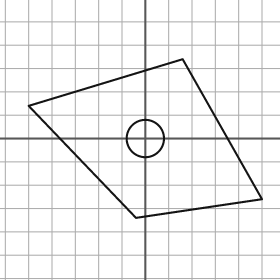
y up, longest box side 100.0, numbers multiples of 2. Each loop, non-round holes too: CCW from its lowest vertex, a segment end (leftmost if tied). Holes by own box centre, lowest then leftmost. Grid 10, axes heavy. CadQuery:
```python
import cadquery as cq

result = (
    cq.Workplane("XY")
    .moveTo(-4.0, -34.0)
    .lineTo(50.0, -26.0)
    .lineTo(16.0, 34.0)
    .lineTo(-50.0, 14.0)
    .close()
    .moveTo(0.0, 0.0)
    .circle(8.0)
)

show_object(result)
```